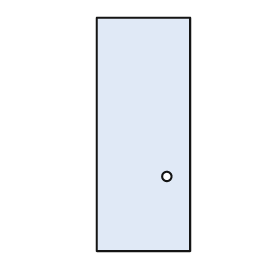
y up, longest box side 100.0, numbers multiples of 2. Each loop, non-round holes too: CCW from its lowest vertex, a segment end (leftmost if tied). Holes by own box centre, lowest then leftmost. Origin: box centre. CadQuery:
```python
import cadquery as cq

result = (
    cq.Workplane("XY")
    .moveTo(-20.0, -50.0)
    .lineTo(20.0, -50.0)
    .lineTo(20.0, 50.0)
    .lineTo(-20.0, 50.0)
    .close()
    .moveTo(10.0, -18.0)
    .circle(2.0)
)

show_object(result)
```